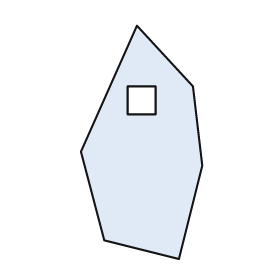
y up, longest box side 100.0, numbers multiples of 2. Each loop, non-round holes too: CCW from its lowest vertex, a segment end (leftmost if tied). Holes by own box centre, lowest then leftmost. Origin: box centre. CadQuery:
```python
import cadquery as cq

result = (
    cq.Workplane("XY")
    .moveTo(16.0, -50.0)
    .lineTo(26.0, -10.0)
    .lineTo(22.0, 24.0)
    .lineTo(-2.0, 50.0)
    .lineTo(-26.0, -4.0)
    .lineTo(-16.0, -42.0)
    .close()
    .moveTo(-6.0, 12.0)
    .lineTo(6.0, 12.0)
    .lineTo(6.0, 24.0)
    .lineTo(-6.0, 24.0)
    .close()
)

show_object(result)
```